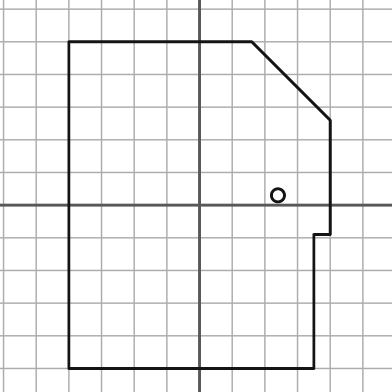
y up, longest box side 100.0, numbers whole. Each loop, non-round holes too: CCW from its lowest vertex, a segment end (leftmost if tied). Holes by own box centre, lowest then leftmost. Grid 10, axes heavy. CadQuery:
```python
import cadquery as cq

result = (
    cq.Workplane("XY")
    .moveTo(-40.0, -50.0)
    .lineTo(35.0, -50.0)
    .lineTo(35.0, -9.0)
    .lineTo(40.0, -9.0)
    .lineTo(40.0, 26.0)
    .lineTo(16.0, 50.0)
    .lineTo(-40.0, 50.0)
    .close()
    .moveTo(24.0, 3.0)
    .circle(2.0)
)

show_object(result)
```